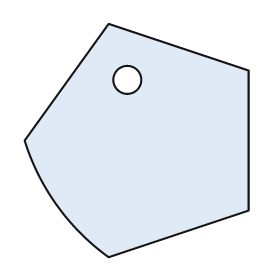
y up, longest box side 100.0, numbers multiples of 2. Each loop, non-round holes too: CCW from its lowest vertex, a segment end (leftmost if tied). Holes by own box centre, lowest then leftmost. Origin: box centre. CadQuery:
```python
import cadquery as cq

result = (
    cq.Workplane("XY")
    .moveTo(-12.0, -50.0)
    .lineTo(48.0, -30.0)
    .lineTo(48.0, 30.0)
    .lineTo(-12.0, 50.0)
    .lineTo(-48.0, 0.0)
    .threePointArc((-34.0, -28.0), (-12.0, -50.0))
    .close()
    .moveTo(-4.0, 26.0)
    .circle(6.0)
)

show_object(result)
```